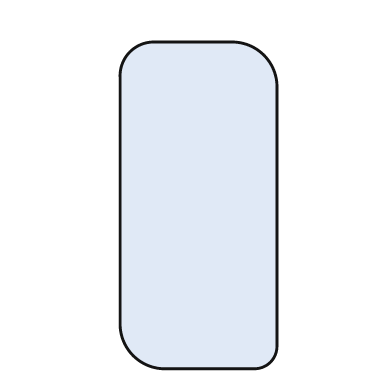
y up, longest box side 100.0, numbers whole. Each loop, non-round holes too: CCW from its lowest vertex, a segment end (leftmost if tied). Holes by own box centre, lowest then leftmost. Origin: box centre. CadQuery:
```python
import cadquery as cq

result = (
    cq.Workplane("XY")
    .moveTo(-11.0, -50.0)
    .lineTo(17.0, -50.0)
    .threePointArc((22.0, -48.0), (24.0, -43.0))
    .lineTo(24.0, 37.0)
    .threePointArc((20.0, 46.0), (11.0, 50.0))
    .lineTo(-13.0, 50.0)
    .threePointArc((-21.0, 47.0), (-24.0, 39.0))
    .lineTo(-24.0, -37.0)
    .threePointArc((-20.0, -46.0), (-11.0, -50.0))
    .close()
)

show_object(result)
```